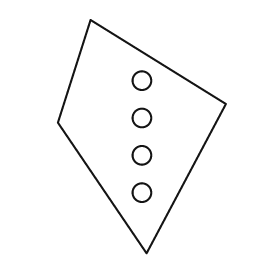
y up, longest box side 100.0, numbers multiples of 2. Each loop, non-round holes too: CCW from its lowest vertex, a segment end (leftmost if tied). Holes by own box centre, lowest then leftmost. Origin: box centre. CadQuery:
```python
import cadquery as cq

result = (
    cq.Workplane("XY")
    .moveTo(2.0, -50.0)
    .lineTo(36.0, 14.0)
    .lineTo(-22.0, 50.0)
    .lineTo(-36.0, 6.0)
    .close()
    .moveTo(0.0, -24.0)
    .circle(4.0)
    .moveTo(0.0, -8.0)
    .circle(4.0)
    .moveTo(0.0, 8.0)
    .circle(4.0)
    .moveTo(0.0, 24.0)
    .circle(4.0)
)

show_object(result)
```